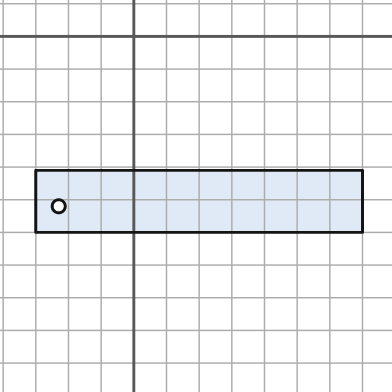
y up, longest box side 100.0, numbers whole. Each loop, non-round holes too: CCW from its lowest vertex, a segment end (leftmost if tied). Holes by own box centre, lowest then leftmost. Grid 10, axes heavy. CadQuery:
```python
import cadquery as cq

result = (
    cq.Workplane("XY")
    .moveTo(-30.0, -60.0)
    .lineTo(70.0, -60.0)
    .lineTo(70.0, -41.0)
    .lineTo(-30.0, -41.0)
    .close()
    .moveTo(-23.0, -52.0)
    .circle(2.0)
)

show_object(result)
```